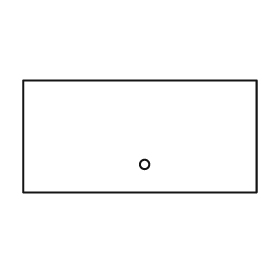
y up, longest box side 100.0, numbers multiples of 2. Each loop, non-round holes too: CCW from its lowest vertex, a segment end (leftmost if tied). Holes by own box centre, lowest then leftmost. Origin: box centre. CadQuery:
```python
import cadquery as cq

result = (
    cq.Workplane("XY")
    .moveTo(-50.0, -24.0)
    .lineTo(50.0, -24.0)
    .lineTo(50.0, 24.0)
    .lineTo(-50.0, 24.0)
    .close()
    .moveTo(2.0, -12.0)
    .circle(2.0)
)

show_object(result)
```